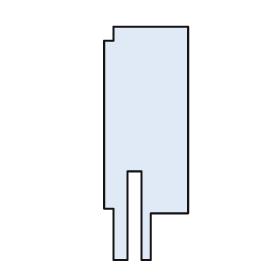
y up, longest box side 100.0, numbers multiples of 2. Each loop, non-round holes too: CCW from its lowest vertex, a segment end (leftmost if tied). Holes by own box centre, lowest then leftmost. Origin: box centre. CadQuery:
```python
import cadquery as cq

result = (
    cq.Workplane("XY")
    .moveTo(-14.0, -50.0)
    .lineTo(-8.0, -50.0)
    .lineTo(-8.0, -12.0)
    .lineTo(-2.0, -12.0)
    .lineTo(-2.0, -50.0)
    .lineTo(2.0, -50.0)
    .lineTo(2.0, -30.0)
    .lineTo(18.0, -30.0)
    .lineTo(18.0, 50.0)
    .lineTo(-14.0, 50.0)
    .lineTo(-14.0, 44.0)
    .lineTo(-18.0, 44.0)
    .lineTo(-18.0, -28.0)
    .lineTo(-14.0, -28.0)
    .close()
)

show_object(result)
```